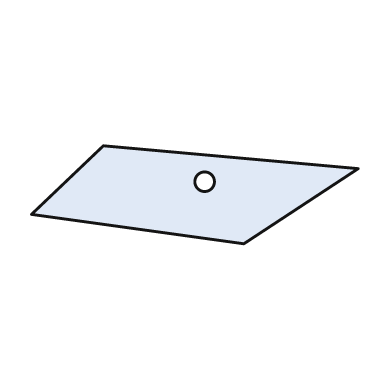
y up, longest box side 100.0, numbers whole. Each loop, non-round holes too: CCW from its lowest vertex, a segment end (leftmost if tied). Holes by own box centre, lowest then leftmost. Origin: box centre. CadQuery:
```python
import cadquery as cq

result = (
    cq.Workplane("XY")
    .moveTo(15.0, -15.0)
    .lineTo(50.0, 8.0)
    .lineTo(-28.0, 15.0)
    .lineTo(-50.0, -6.0)
    .close()
    .moveTo(3.0, 4.0)
    .circle(3.0)
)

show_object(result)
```